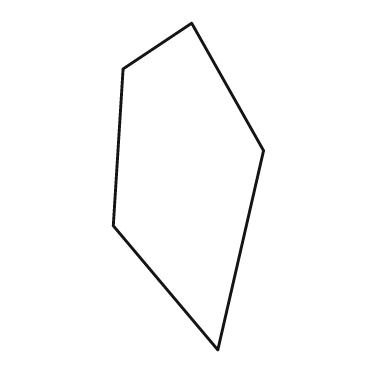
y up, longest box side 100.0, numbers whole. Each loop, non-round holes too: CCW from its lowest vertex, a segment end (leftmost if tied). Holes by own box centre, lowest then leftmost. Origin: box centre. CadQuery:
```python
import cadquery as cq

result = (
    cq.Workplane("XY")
    .moveTo(9.0, -50.0)
    .lineTo(23.0, 11.0)
    .lineTo(1.0, 50.0)
    .lineTo(-20.0, 36.0)
    .lineTo(-23.0, -12.0)
    .close()
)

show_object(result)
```